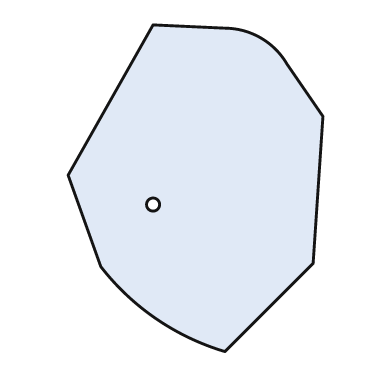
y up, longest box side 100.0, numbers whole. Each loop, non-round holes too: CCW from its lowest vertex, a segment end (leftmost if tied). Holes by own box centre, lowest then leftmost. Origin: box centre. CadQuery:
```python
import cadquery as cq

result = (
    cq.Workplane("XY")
    .moveTo(9.0, -50.0)
    .lineTo(36.0, -23.0)
    .lineTo(39.0, 22.0)
    .lineTo(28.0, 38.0)
    .threePointArc((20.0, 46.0), (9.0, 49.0))
    .lineTo(-13.0, 50.0)
    .lineTo(-39.0, 4.0)
    .lineTo(-29.0, -24.0)
    .threePointArc((-12.0, -40.0), (9.0, -50.0))
    .close()
    .moveTo(-13.0, -5.0)
    .circle(2.0)
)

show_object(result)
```